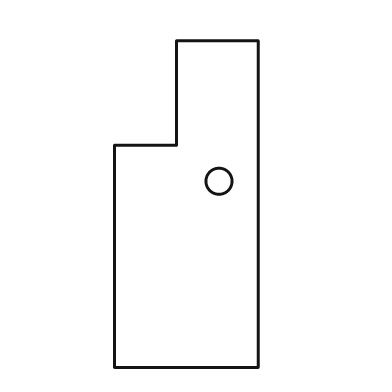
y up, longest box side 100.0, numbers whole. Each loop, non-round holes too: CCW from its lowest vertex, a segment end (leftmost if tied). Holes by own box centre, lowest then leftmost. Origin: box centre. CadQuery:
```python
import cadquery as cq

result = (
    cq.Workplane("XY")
    .moveTo(-22.0, -50.0)
    .lineTo(22.0, -50.0)
    .lineTo(22.0, 50.0)
    .lineTo(-3.0, 50.0)
    .lineTo(-3.0, 18.0)
    .lineTo(-22.0, 18.0)
    .close()
    .moveTo(10.0, 7.0)
    .circle(4.0)
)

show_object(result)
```